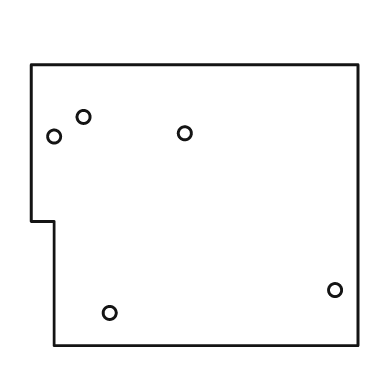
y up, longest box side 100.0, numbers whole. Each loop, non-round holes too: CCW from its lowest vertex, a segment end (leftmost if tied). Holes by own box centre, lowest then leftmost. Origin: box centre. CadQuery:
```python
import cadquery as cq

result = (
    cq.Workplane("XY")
    .moveTo(-43.0, -43.0)
    .lineTo(50.0, -43.0)
    .lineTo(50.0, 43.0)
    .lineTo(-50.0, 43.0)
    .lineTo(-50.0, -5.0)
    .lineTo(-43.0, -5.0)
    .close()
    .moveTo(-26.0, -33.0)
    .circle(2.0)
    .moveTo(43.0, -26.0)
    .circle(2.0)
    .moveTo(-43.0, 21.0)
    .circle(2.0)
    .moveTo(-3.0, 22.0)
    .circle(2.0)
    .moveTo(-34.0, 27.0)
    .circle(2.0)
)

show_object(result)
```